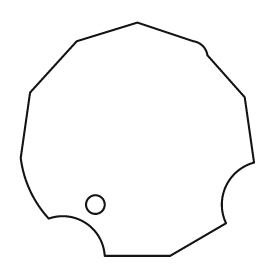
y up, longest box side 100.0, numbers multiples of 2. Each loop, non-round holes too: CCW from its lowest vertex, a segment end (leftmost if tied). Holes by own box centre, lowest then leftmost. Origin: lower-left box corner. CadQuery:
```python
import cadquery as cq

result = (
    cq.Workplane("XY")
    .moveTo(36.0, 0.0)
    .lineTo(64.0, 0.0)
    .lineTo(88.0, 14.0)
    .threePointArc((88.0, 30.0), (100.0, 40.0))
    .lineTo(96.0, 68.0)
    .lineTo(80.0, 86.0)
    .threePointArc((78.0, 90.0), (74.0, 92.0))
    .lineTo(50.0, 100.0)
    .lineTo(24.0, 92.0)
    .lineTo(4.0, 70.0)
    .lineTo(0.0, 42.0)
    .threePointArc((4.0, 28.0), (12.0, 16.0))
    .threePointArc((28.0, 14.0), (36.0, 0.0))
    .close()
    .moveTo(32.0, 22.0)
    .circle(4.0)
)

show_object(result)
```